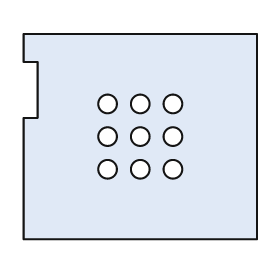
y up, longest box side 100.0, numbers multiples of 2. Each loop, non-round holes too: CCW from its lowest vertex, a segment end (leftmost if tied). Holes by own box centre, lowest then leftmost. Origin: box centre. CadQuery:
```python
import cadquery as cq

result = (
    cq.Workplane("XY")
    .moveTo(-50.0, -44.0)
    .lineTo(50.0, -44.0)
    .lineTo(50.0, 44.0)
    .lineTo(-50.0, 44.0)
    .lineTo(-50.0, 32.0)
    .lineTo(-44.0, 32.0)
    .lineTo(-44.0, 8.0)
    .lineTo(-50.0, 8.0)
    .close()
    .moveTo(-14.0, -14.0)
    .circle(4.0)
    .moveTo(0.0, -14.0)
    .circle(4.0)
    .moveTo(14.0, -14.0)
    .circle(4.0)
    .moveTo(-14.0, 0.0)
    .circle(4.0)
    .moveTo(0.0, 0.0)
    .circle(4.0)
    .moveTo(14.0, 0.0)
    .circle(4.0)
    .moveTo(-14.0, 14.0)
    .circle(4.0)
    .moveTo(0.0, 14.0)
    .circle(4.0)
    .moveTo(14.0, 14.0)
    .circle(4.0)
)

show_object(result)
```